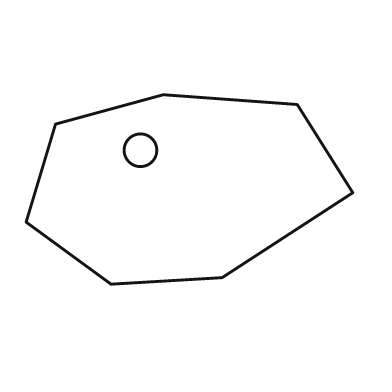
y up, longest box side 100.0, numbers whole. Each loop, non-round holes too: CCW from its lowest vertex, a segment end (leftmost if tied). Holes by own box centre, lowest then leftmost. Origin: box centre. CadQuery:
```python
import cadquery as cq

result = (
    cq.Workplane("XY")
    .moveTo(-24.0, -29.0)
    .lineTo(10.0, -27.0)
    .lineTo(50.0, -1.0)
    .lineTo(33.0, 26.0)
    .lineTo(-8.0, 29.0)
    .lineTo(-41.0, 20.0)
    .lineTo(-50.0, -10.0)
    .close()
    .moveTo(-15.0, 12.0)
    .circle(5.0)
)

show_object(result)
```